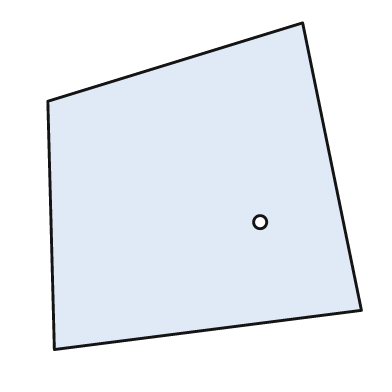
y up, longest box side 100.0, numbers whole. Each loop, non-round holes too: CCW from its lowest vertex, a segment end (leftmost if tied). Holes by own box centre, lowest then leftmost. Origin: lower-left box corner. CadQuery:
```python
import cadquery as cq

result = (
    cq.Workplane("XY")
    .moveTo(2.0, 0.0)
    .lineTo(96.0, 12.0)
    .lineTo(78.0, 100.0)
    .lineTo(0.0, 76.0)
    .close()
    .moveTo(65.0, 39.0)
    .circle(2.0)
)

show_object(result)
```